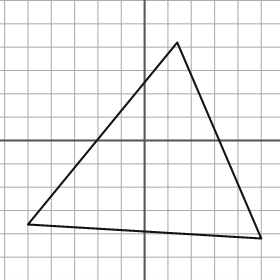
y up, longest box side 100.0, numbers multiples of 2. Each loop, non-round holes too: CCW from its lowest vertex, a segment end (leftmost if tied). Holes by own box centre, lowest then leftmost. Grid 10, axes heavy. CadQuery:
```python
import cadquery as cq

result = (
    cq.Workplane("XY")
    .moveTo(50.0, -42.0)
    .lineTo(14.0, 42.0)
    .lineTo(-50.0, -36.0)
    .close()
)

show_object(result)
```